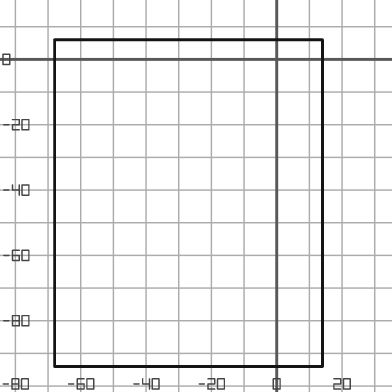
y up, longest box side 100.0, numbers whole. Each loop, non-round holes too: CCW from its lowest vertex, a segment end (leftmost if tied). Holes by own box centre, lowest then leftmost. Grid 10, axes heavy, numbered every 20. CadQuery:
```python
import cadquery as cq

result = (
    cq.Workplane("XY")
    .moveTo(-68.0, -94.0)
    .lineTo(14.0, -94.0)
    .lineTo(14.0, 6.0)
    .lineTo(-68.0, 6.0)
    .close()
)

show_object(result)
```